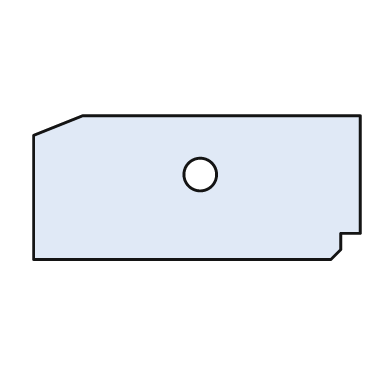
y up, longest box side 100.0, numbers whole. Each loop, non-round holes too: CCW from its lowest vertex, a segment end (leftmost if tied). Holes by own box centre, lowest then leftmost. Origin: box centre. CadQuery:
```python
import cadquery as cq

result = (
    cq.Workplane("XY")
    .moveTo(-50.0, -22.0)
    .lineTo(41.0, -22.0)
    .lineTo(44.0, -19.0)
    .lineTo(44.0, -14.0)
    .lineTo(50.0, -14.0)
    .lineTo(50.0, 22.0)
    .lineTo(-35.0, 22.0)
    .lineTo(-50.0, 16.0)
    .close()
    .moveTo(1.0, 4.0)
    .circle(5.0)
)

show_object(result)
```